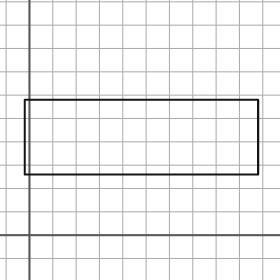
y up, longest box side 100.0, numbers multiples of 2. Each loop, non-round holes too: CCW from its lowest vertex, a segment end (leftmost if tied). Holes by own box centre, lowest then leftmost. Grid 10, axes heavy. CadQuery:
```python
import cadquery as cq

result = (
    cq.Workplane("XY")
    .moveTo(-2.0, 26.0)
    .lineTo(98.0, 26.0)
    .lineTo(98.0, 58.0)
    .lineTo(-2.0, 58.0)
    .close()
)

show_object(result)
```